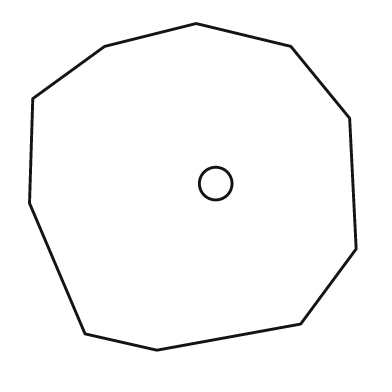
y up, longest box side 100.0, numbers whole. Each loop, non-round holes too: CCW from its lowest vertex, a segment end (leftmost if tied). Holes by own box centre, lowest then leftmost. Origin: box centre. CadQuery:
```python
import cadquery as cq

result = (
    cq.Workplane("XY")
    .moveTo(-11.0, -50.0)
    .lineTo(33.0, -42.0)
    .lineTo(50.0, -19.0)
    .lineTo(48.0, 21.0)
    .lineTo(30.0, 43.0)
    .lineTo(1.0, 50.0)
    .lineTo(-27.0, 43.0)
    .lineTo(-49.0, 27.0)
    .lineTo(-50.0, -5.0)
    .lineTo(-33.0, -45.0)
    .close()
    .moveTo(7.0, 1.0)
    .circle(5.0)
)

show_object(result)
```